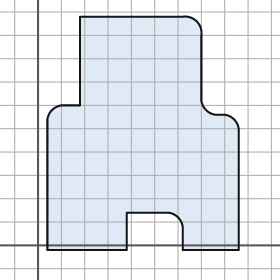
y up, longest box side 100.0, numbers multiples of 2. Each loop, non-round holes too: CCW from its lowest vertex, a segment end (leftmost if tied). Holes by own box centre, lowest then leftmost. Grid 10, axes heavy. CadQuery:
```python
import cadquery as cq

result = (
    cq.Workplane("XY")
    .moveTo(4.0, -2.0)
    .lineTo(38.0, -2.0)
    .lineTo(38.0, 14.0)
    .lineTo(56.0, 14.0)
    .threePointArc((60.0, 12.0), (62.0, 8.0))
    .lineTo(62.0, -2.0)
    .lineTo(86.0, -2.0)
    .lineTo(86.0, 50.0)
    .threePointArc((84.0, 54.0), (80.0, 56.0))
    .lineTo(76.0, 56.0)
    .threePointArc((72.0, 58.0), (70.0, 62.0))
    .lineTo(70.0, 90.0)
    .threePointArc((68.0, 96.0), (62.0, 98.0))
    .lineTo(18.0, 98.0)
    .lineTo(18.0, 60.0)
    .lineTo(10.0, 60.0)
    .threePointArc((6.0, 58.0), (4.0, 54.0))
    .close()
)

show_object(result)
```